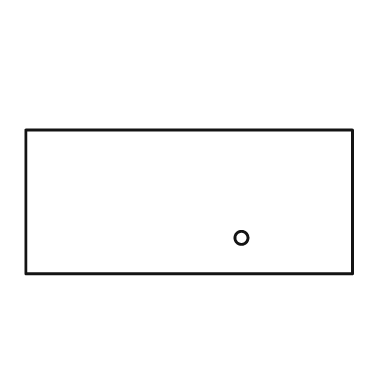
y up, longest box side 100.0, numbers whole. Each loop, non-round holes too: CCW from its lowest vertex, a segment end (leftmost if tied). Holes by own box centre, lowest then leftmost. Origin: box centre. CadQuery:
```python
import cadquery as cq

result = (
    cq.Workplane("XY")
    .moveTo(-50.0, -22.0)
    .lineTo(50.0, -22.0)
    .lineTo(50.0, 22.0)
    .lineTo(-50.0, 22.0)
    .close()
    .moveTo(16.0, -11.0)
    .circle(2.0)
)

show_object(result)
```